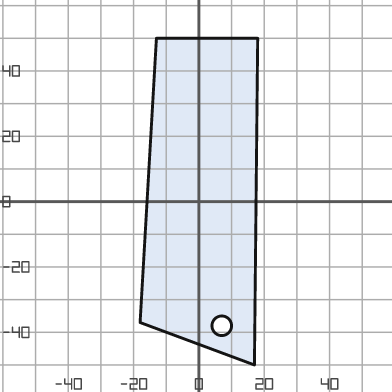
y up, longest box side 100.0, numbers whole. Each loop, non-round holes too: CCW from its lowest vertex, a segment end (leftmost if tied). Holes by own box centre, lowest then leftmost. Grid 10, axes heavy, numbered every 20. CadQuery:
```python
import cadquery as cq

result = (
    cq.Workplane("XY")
    .moveTo(17.0, -50.0)
    .lineTo(18.0, 50.0)
    .lineTo(-13.0, 50.0)
    .lineTo(-18.0, -37.0)
    .close()
    .moveTo(7.0, -38.0)
    .circle(3.0)
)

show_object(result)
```